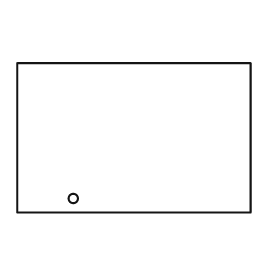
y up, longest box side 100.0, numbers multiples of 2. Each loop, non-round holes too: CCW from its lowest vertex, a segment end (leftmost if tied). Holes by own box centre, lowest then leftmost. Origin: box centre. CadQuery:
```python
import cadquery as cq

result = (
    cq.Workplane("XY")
    .moveTo(-50.0, -32.0)
    .lineTo(50.0, -32.0)
    .lineTo(50.0, 32.0)
    .lineTo(-50.0, 32.0)
    .close()
    .moveTo(-26.0, -26.0)
    .circle(2.0)
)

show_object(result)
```